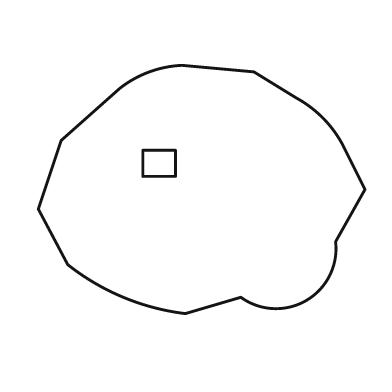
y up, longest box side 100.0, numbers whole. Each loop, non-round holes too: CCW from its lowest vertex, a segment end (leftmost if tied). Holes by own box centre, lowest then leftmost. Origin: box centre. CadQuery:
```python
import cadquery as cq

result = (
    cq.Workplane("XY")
    .moveTo(-5.0, -38.0)
    .lineTo(12.0, -33.0)
    .threePointArc((32.0, -34.0), (41.0, -16.0))
    .lineTo(50.0, 0.0)
    .lineTo(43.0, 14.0)
    .threePointArc((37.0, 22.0), (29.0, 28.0))
    .lineTo(16.0, 36.0)
    .lineTo(-6.0, 38.0)
    .threePointArc((-16.0, 36.0), (-25.0, 31.0))
    .lineTo(-43.0, 15.0)
    .lineTo(-50.0, -6.0)
    .lineTo(-41.0, -23.0)
    .threePointArc((-24.0, -33.0), (-5.0, -38.0))
    .close()
    .moveTo(-18.0, 4.0)
    .lineTo(-8.0, 4.0)
    .lineTo(-8.0, 12.0)
    .lineTo(-18.0, 12.0)
    .close()
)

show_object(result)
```